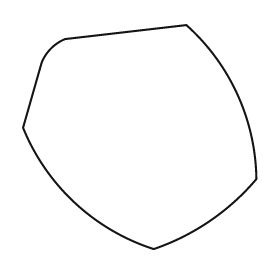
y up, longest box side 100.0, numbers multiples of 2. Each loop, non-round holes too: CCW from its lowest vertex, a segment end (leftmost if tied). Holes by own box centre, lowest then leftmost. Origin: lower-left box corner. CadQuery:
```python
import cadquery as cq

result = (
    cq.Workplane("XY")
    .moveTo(56.0, 0.0)
    .threePointArc((80.0, 12.0), (100.0, 30.0))
    .threePointArc((92.0, 66.0), (70.0, 96.0))
    .lineTo(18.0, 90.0)
    .threePointArc((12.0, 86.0), (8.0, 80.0))
    .lineTo(0.0, 52.0)
    .threePointArc((22.0, 20.0), (56.0, 0.0))
    .close()
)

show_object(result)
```